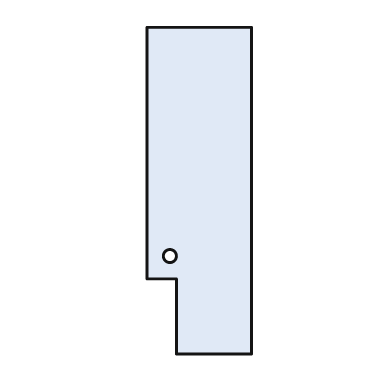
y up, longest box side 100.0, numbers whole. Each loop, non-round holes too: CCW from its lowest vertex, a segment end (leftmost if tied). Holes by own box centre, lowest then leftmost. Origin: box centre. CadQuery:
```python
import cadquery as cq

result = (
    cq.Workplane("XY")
    .moveTo(-7.0, -50.0)
    .lineTo(16.0, -50.0)
    .lineTo(16.0, 50.0)
    .lineTo(-16.0, 50.0)
    .lineTo(-16.0, -27.0)
    .lineTo(-7.0, -27.0)
    .close()
    .moveTo(-9.0, -20.0)
    .circle(2.0)
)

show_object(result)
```